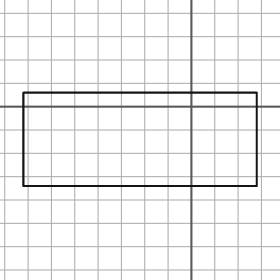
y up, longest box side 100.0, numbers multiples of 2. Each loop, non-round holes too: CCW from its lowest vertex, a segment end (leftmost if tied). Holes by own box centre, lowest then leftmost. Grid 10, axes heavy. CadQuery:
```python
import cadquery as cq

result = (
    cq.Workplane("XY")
    .moveTo(-72.0, -34.0)
    .lineTo(28.0, -34.0)
    .lineTo(28.0, 6.0)
    .lineTo(-72.0, 6.0)
    .close()
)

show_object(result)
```